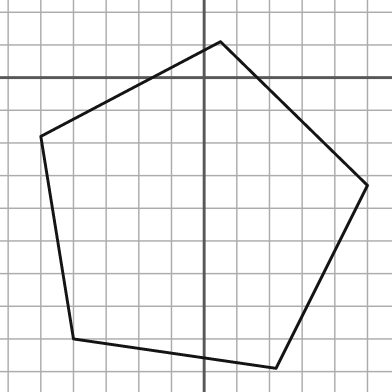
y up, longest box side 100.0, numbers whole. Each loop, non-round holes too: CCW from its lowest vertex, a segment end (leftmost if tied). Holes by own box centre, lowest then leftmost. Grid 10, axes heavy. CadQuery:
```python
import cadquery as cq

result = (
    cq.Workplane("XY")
    .moveTo(22.0, -89.0)
    .lineTo(50.0, -33.0)
    .lineTo(5.0, 11.0)
    .lineTo(-50.0, -18.0)
    .lineTo(-40.0, -80.0)
    .close()
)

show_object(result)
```